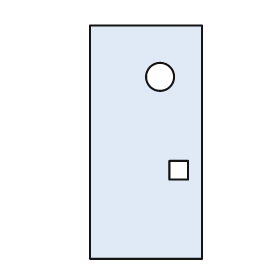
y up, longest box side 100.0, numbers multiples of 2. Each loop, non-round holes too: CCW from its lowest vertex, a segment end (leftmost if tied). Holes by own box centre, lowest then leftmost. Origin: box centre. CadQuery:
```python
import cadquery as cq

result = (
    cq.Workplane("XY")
    .moveTo(-24.0, -50.0)
    .lineTo(24.0, -50.0)
    .lineTo(24.0, 50.0)
    .lineTo(-24.0, 50.0)
    .close()
    .moveTo(10.0, -16.0)
    .lineTo(18.0, -16.0)
    .lineTo(18.0, -8.0)
    .lineTo(10.0, -8.0)
    .close()
    .moveTo(6.0, 28.0)
    .circle(6.0)
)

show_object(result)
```